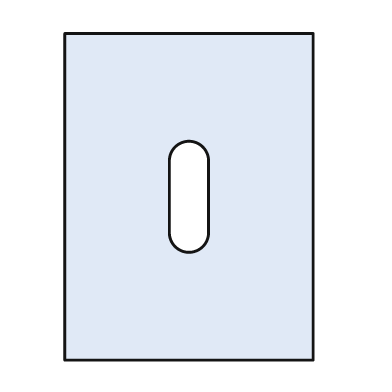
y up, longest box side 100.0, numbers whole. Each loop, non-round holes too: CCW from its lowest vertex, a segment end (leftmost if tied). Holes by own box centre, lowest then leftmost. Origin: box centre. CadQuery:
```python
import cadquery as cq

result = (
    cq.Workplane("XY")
    .moveTo(-38.0, -50.0)
    .lineTo(38.0, -50.0)
    .lineTo(38.0, 50.0)
    .lineTo(-38.0, 50.0)
    .close()
    .moveTo(-6.0, -11.0)
    .threePointArc((0.0, -17.0), (6.0, -11.0))
    .lineTo(6.0, 11.0)
    .threePointArc((0.0, 17.0), (-6.0, 11.0))
    .close()
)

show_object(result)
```